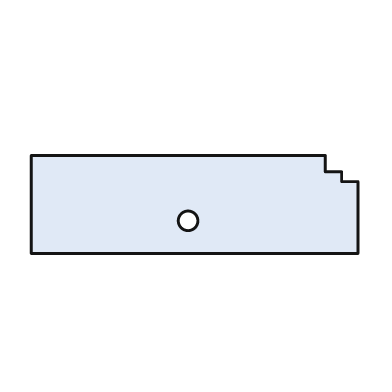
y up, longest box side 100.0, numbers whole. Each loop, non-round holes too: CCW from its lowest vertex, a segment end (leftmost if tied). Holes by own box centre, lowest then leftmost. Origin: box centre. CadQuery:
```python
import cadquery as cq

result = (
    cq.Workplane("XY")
    .moveTo(-50.0, -15.0)
    .lineTo(50.0, -15.0)
    .lineTo(50.0, 7.0)
    .lineTo(45.0, 7.0)
    .lineTo(45.0, 10.0)
    .lineTo(40.0, 10.0)
    .lineTo(40.0, 15.0)
    .lineTo(-50.0, 15.0)
    .close()
    .moveTo(-2.0, -5.0)
    .circle(3.0)
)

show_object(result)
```